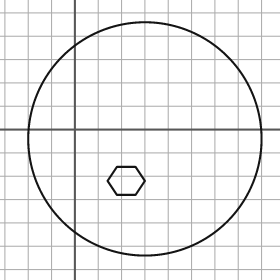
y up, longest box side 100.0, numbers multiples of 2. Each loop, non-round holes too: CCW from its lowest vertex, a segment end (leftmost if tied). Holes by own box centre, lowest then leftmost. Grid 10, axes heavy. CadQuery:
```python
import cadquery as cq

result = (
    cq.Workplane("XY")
    .moveTo(30.0, -4.0)
    .circle(50.0)
    .moveTo(18.0, -28.0)
    .lineTo(26.0, -28.0)
    .lineTo(30.0, -22.0)
    .lineTo(26.0, -16.0)
    .lineTo(18.0, -16.0)
    .lineTo(14.0, -22.0)
    .close()
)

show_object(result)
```